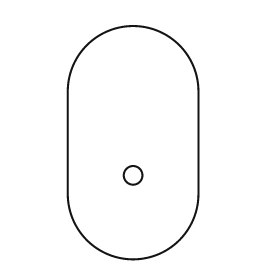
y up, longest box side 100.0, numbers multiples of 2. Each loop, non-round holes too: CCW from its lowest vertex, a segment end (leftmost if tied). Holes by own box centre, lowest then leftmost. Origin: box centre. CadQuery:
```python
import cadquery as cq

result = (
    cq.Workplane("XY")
    .moveTo(-28.0, -22.0)
    .threePointArc((0.0, -50.0), (28.0, -22.0))
    .lineTo(28.0, 22.0)
    .threePointArc((0.0, 50.0), (-28.0, 22.0))
    .close()
    .moveTo(0.0, -14.0)
    .circle(4.0)
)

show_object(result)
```